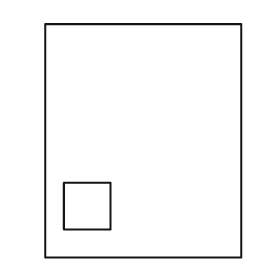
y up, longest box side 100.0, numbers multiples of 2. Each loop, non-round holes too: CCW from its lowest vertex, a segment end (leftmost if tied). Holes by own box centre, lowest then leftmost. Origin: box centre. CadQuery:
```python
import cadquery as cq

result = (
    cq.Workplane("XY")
    .moveTo(-42.0, -50.0)
    .lineTo(42.0, -50.0)
    .lineTo(42.0, 50.0)
    .lineTo(-42.0, 50.0)
    .close()
    .moveTo(-34.0, -38.0)
    .lineTo(-14.0, -38.0)
    .lineTo(-14.0, -18.0)
    .lineTo(-34.0, -18.0)
    .close()
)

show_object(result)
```